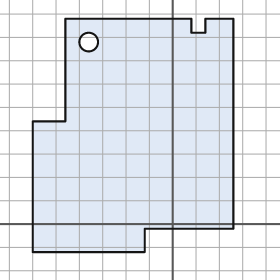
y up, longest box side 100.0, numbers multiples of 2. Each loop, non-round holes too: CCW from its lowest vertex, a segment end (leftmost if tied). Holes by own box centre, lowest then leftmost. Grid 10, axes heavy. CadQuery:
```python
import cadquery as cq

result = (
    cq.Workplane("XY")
    .moveTo(-60.0, -12.0)
    .lineTo(-12.0, -12.0)
    .lineTo(-12.0, -2.0)
    .lineTo(26.0, -2.0)
    .lineTo(26.0, 88.0)
    .lineTo(14.0, 88.0)
    .lineTo(14.0, 82.0)
    .lineTo(8.0, 82.0)
    .lineTo(8.0, 88.0)
    .lineTo(-46.0, 88.0)
    .lineTo(-46.0, 44.0)
    .lineTo(-60.0, 44.0)
    .close()
    .moveTo(-36.0, 78.0)
    .circle(4.0)
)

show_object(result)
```